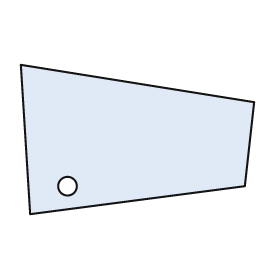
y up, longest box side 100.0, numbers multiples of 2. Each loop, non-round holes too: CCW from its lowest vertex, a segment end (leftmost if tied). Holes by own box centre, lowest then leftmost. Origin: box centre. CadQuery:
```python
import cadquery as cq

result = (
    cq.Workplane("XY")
    .moveTo(-46.0, -32.0)
    .lineTo(46.0, -20.0)
    .lineTo(50.0, 16.0)
    .lineTo(-50.0, 32.0)
    .close()
    .moveTo(-30.0, -20.0)
    .circle(4.0)
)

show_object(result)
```